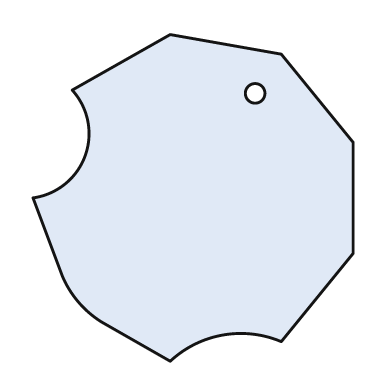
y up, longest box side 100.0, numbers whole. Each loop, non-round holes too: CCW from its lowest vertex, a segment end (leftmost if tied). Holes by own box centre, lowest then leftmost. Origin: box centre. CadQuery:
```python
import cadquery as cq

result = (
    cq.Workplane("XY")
    .moveTo(-7.0, -50.0)
    .threePointArc((9.0, -42.0), (27.0, -44.0))
    .lineTo(49.0, -17.0)
    .lineTo(49.0, 17.0)
    .lineTo(27.0, 44.0)
    .lineTo(-7.0, 50.0)
    .lineTo(-37.0, 33.0)
    .threePointArc((-33.0, 13.0), (-49.0, 0.0))
    .lineTo(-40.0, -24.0)
    .threePointArc((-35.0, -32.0), (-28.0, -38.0))
    .close()
    .moveTo(19.0, 32.0)
    .circle(3.0)
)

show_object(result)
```